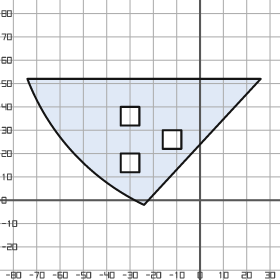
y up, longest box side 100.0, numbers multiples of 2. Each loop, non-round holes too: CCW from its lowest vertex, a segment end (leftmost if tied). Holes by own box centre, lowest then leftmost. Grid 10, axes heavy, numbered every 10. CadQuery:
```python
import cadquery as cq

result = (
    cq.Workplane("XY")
    .moveTo(-24.0, -2.0)
    .lineTo(26.0, 52.0)
    .lineTo(-74.0, 52.0)
    .threePointArc((-54.0, 20.0), (-24.0, -2.0))
    .close()
    .moveTo(-34.0, 12.0)
    .lineTo(-26.0, 12.0)
    .lineTo(-26.0, 20.0)
    .lineTo(-34.0, 20.0)
    .close()
    .moveTo(-16.0, 22.0)
    .lineTo(-8.0, 22.0)
    .lineTo(-8.0, 30.0)
    .lineTo(-16.0, 30.0)
    .close()
    .moveTo(-34.0, 32.0)
    .lineTo(-26.0, 32.0)
    .lineTo(-26.0, 40.0)
    .lineTo(-34.0, 40.0)
    .close()
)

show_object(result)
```